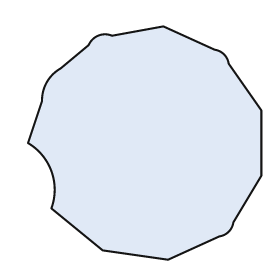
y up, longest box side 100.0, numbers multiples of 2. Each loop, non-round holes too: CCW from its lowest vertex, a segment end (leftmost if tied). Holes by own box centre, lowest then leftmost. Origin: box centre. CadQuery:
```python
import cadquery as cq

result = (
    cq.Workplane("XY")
    .moveTo(10.0, -50.0)
    .lineTo(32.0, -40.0)
    .threePointArc((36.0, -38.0), (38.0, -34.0))
    .lineTo(50.0, -14.0)
    .lineTo(50.0, 14.0)
    .lineTo(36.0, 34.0)
    .threePointArc((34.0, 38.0), (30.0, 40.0))
    .lineTo(8.0, 50.0)
    .lineTo(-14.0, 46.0)
    .threePointArc((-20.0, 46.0), (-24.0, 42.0))
    .lineTo(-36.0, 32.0)
    .threePointArc((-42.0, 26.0), (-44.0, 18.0))
    .lineTo(-50.0, 0.0)
    .threePointArc((-40.0, -12.0), (-40.0, -28.0))
    .lineTo(-18.0, -46.0)
    .close()
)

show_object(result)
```